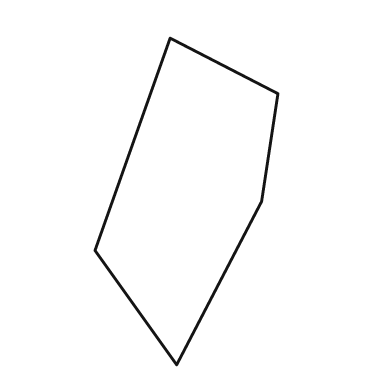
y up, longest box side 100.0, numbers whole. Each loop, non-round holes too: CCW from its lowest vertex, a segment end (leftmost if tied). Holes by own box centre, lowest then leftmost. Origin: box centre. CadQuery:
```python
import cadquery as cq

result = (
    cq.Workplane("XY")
    .moveTo(-3.0, -50.0)
    .lineTo(23.0, 0.0)
    .lineTo(28.0, 33.0)
    .lineTo(-5.0, 50.0)
    .lineTo(-28.0, -15.0)
    .close()
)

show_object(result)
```